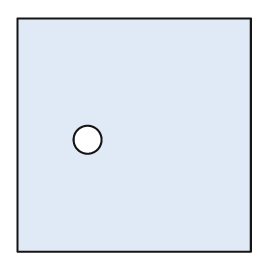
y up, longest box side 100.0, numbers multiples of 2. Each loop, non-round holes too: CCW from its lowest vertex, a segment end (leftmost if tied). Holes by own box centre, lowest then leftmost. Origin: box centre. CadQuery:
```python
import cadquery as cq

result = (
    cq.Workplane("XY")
    .moveTo(-50.0, -50.0)
    .lineTo(50.0, -50.0)
    .lineTo(50.0, 50.0)
    .lineTo(-50.0, 50.0)
    .close()
    .moveTo(-20.0, -2.0)
    .circle(6.0)
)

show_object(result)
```